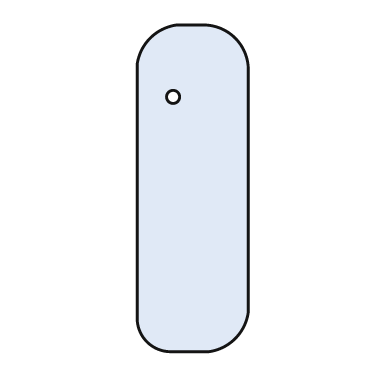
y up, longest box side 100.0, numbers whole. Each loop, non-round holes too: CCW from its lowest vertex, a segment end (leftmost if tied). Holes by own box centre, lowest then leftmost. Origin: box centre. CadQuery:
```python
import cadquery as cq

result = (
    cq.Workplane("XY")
    .moveTo(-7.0, -50.0)
    .lineTo(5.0, -50.0)
    .threePointArc((13.0, -46.0), (17.0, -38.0))
    .lineTo(17.0, 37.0)
    .threePointArc((13.0, 46.0), (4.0, 50.0))
    .lineTo(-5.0, 50.0)
    .threePointArc((-13.0, 46.0), (-17.0, 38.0))
    .lineTo(-17.0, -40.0)
    .threePointArc((-14.0, -47.0), (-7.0, -50.0))
    .close()
    .moveTo(-6.0, 28.0)
    .circle(2.0)
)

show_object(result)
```